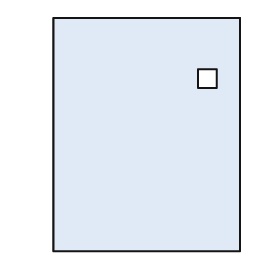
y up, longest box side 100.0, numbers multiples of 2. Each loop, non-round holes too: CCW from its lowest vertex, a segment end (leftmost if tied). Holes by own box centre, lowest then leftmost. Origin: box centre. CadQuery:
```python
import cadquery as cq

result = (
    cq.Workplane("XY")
    .moveTo(-40.0, -50.0)
    .lineTo(40.0, -50.0)
    .lineTo(40.0, 50.0)
    .lineTo(-40.0, 50.0)
    .close()
    .moveTo(22.0, 20.0)
    .lineTo(30.0, 20.0)
    .lineTo(30.0, 28.0)
    .lineTo(22.0, 28.0)
    .close()
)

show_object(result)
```